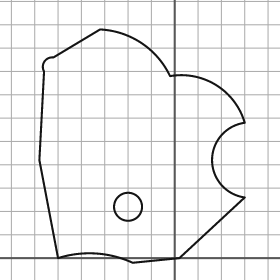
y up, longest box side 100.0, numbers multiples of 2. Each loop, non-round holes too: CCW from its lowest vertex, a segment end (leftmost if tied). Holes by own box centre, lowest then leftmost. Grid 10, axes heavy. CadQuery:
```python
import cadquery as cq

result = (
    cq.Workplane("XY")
    .moveTo(-18.0, -2.0)
    .lineTo(2.0, 0.0)
    .lineTo(30.0, 26.0)
    .threePointArc((16.0, 42.0), (30.0, 58.0))
    .threePointArc((18.0, 74.0), (-2.0, 78.0))
    .threePointArc((-14.0, 92.0), (-32.0, 98.0))
    .lineTo(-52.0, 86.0)
    .threePointArc((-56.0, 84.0), (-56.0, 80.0))
    .lineTo(-58.0, 42.0)
    .lineTo(-50.0, 0.0)
    .threePointArc((-34.0, 2.0), (-18.0, -2.0))
    .close()
    .moveTo(-20.0, 22.0)
    .circle(6.0)
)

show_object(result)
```